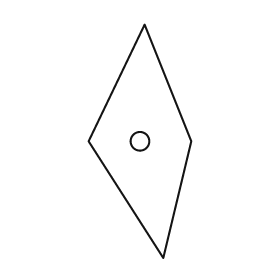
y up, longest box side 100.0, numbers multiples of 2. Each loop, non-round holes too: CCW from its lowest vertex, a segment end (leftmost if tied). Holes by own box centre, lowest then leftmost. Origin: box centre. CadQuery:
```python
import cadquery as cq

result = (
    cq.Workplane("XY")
    .moveTo(10.0, -50.0)
    .lineTo(22.0, 0.0)
    .lineTo(2.0, 50.0)
    .lineTo(-22.0, 0.0)
    .close()
    .moveTo(0.0, 0.0)
    .circle(4.0)
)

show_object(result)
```